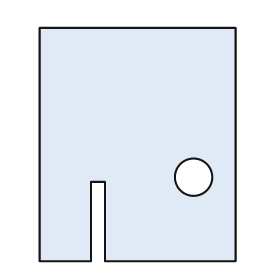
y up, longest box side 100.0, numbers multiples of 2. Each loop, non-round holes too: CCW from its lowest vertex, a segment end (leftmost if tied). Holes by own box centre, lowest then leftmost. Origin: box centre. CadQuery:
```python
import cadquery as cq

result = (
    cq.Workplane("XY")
    .moveTo(-42.0, -50.0)
    .lineTo(-20.0, -50.0)
    .lineTo(-20.0, -16.0)
    .lineTo(-14.0, -16.0)
    .lineTo(-14.0, -50.0)
    .lineTo(42.0, -50.0)
    .lineTo(42.0, 50.0)
    .lineTo(-42.0, 50.0)
    .close()
    .moveTo(24.0, -14.0)
    .circle(8.0)
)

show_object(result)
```